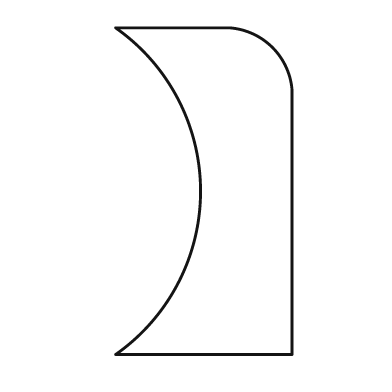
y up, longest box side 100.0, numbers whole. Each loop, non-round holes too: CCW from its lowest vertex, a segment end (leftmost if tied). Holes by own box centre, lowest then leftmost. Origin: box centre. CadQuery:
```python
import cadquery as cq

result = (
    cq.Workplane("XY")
    .moveTo(-27.0, -50.0)
    .lineTo(27.0, -50.0)
    .lineTo(27.0, 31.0)
    .threePointArc((21.0, 44.0), (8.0, 50.0))
    .lineTo(-27.0, 50.0)
    .threePointArc((-1.0, 0.0), (-27.0, -50.0))
    .close()
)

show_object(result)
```